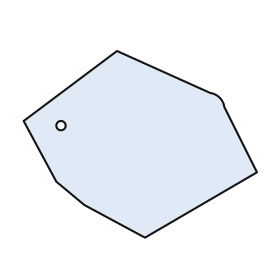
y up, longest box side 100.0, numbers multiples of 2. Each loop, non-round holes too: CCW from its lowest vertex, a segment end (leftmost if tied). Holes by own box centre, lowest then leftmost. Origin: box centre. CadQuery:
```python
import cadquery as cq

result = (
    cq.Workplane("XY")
    .moveTo(2.0, -40.0)
    .lineTo(50.0, -12.0)
    .lineTo(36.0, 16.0)
    .threePointArc((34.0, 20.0), (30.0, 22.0))
    .lineTo(-10.0, 40.0)
    .lineTo(-50.0, 10.0)
    .lineTo(-36.0, -16.0)
    .lineTo(-24.0, -26.0)
    .close()
    .moveTo(-34.0, 8.0)
    .circle(2.0)
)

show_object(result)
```